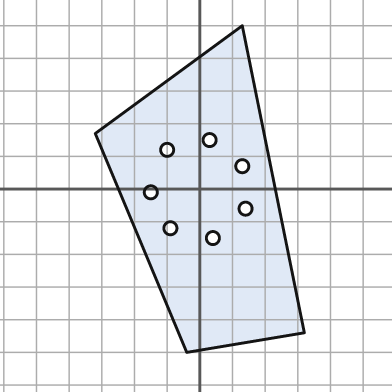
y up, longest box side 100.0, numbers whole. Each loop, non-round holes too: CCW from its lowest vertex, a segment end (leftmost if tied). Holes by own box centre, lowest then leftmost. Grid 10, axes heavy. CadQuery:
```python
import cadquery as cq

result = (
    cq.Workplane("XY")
    .moveTo(-4.0, -50.0)
    .lineTo(32.0, -44.0)
    .lineTo(13.0, 50.0)
    .lineTo(-32.0, 17.0)
    .close()
    .moveTo(4.0, -15.0)
    .circle(2.0)
    .moveTo(-9.0, -12.0)
    .circle(2.0)
    .moveTo(14.0, -6.0)
    .circle(2.0)
    .moveTo(-15.0, -1.0)
    .circle(2.0)
    .moveTo(13.0, 7.0)
    .circle(2.0)
    .moveTo(-10.0, 12.0)
    .circle(2.0)
    .moveTo(3.0, 15.0)
    .circle(2.0)
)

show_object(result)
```